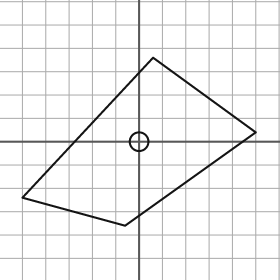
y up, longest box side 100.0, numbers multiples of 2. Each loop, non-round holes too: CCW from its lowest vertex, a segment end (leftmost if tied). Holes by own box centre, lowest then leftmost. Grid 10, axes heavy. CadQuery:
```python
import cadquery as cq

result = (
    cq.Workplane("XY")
    .moveTo(-6.0, -36.0)
    .lineTo(50.0, 4.0)
    .lineTo(6.0, 36.0)
    .lineTo(-50.0, -24.0)
    .close()
    .moveTo(0.0, 0.0)
    .circle(4.0)
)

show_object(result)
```